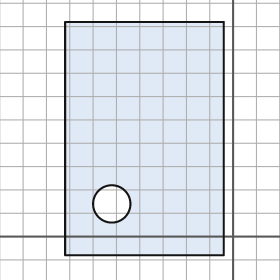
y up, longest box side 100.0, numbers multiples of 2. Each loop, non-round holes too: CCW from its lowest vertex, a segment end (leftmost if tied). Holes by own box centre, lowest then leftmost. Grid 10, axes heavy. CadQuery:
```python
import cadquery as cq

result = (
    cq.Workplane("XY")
    .moveTo(-72.0, -8.0)
    .lineTo(-4.0, -8.0)
    .lineTo(-4.0, 92.0)
    .lineTo(-72.0, 92.0)
    .close()
    .moveTo(-52.0, 14.0)
    .circle(8.0)
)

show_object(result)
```